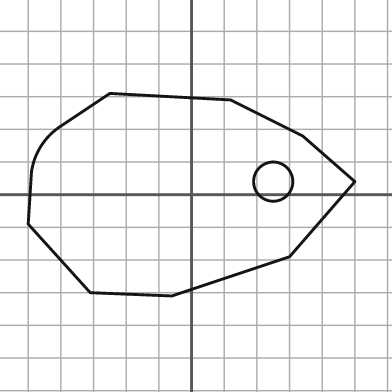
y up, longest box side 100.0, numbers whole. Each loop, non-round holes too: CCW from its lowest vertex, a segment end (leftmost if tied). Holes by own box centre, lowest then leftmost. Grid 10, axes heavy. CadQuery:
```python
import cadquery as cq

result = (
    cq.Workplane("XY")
    .moveTo(-6.0, -31.0)
    .lineTo(30.0, -19.0)
    .lineTo(50.0, 4.0)
    .lineTo(34.0, 18.0)
    .lineTo(12.0, 29.0)
    .lineTo(-25.0, 31.0)
    .lineTo(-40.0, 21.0)
    .threePointArc((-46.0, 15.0), (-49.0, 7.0))
    .lineTo(-50.0, -9.0)
    .lineTo(-31.0, -30.0)
    .close()
    .moveTo(25.0, 4.0)
    .circle(6.0)
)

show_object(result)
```